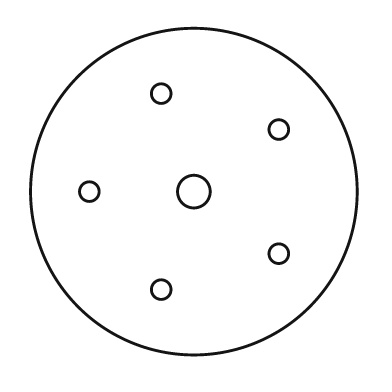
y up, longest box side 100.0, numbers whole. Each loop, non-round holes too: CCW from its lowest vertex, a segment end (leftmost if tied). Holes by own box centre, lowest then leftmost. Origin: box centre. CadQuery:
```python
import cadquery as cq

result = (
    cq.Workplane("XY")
    .moveTo(0.0, 0.0)
    .circle(50.0)
    .moveTo(-10.0, -30.0)
    .circle(3.0)
    .moveTo(26.0, -19.0)
    .circle(3.0)
    .moveTo(-32.0, 0.0)
    .circle(3.0)
    .moveTo(0.0, 0.0)
    .circle(5.0)
    .moveTo(26.0, 19.0)
    .circle(3.0)
    .moveTo(-10.0, 30.0)
    .circle(3.0)
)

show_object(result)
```